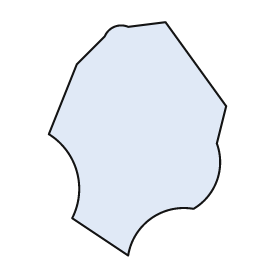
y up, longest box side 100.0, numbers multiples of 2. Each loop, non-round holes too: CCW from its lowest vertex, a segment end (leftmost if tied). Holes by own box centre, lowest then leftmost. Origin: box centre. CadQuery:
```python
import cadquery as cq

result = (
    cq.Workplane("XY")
    .moveTo(-4.0, -50.0)
    .threePointArc((6.0, -34.0), (24.0, -30.0))
    .threePointArc((34.0, -18.0), (34.0, -2.0))
    .lineTo(38.0, 14.0)
    .lineTo(12.0, 50.0)
    .lineTo(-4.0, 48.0)
    .threePointArc((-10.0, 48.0), (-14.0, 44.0))
    .lineTo(-26.0, 32.0)
    .lineTo(-38.0, 2.0)
    .threePointArc((-26.0, -14.0), (-28.0, -34.0))
    .close()
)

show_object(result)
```